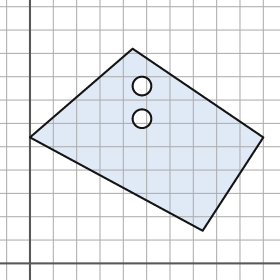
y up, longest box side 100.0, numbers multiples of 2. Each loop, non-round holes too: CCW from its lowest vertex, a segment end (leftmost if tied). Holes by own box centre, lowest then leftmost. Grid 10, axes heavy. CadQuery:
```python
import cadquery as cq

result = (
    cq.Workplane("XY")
    .moveTo(74.0, 14.0)
    .lineTo(100.0, 54.0)
    .lineTo(44.0, 92.0)
    .lineTo(0.0, 54.0)
    .close()
    .moveTo(48.0, 62.0)
    .circle(4.0)
    .moveTo(48.0, 76.0)
    .circle(4.0)
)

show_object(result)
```